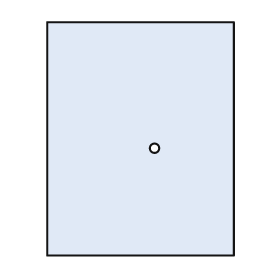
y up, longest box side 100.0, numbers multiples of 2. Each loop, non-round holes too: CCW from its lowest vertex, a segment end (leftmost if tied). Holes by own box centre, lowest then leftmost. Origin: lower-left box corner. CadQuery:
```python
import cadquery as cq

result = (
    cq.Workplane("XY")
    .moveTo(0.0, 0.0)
    .lineTo(80.0, 0.0)
    .lineTo(80.0, 100.0)
    .lineTo(0.0, 100.0)
    .close()
    .moveTo(46.0, 46.0)
    .circle(2.0)
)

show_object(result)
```